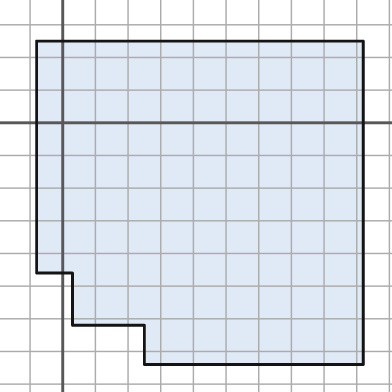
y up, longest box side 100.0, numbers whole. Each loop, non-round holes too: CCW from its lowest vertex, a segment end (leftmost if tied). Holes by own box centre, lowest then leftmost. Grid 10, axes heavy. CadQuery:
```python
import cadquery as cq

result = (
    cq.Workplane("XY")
    .moveTo(25.0, -74.0)
    .lineTo(92.0, -74.0)
    .lineTo(92.0, 25.0)
    .lineTo(-8.0, 25.0)
    .lineTo(-8.0, -46.0)
    .lineTo(3.0, -46.0)
    .lineTo(3.0, -62.0)
    .lineTo(25.0, -62.0)
    .close()
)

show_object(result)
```